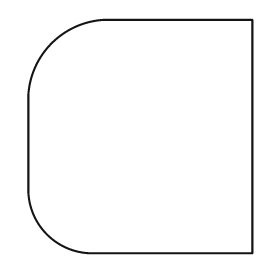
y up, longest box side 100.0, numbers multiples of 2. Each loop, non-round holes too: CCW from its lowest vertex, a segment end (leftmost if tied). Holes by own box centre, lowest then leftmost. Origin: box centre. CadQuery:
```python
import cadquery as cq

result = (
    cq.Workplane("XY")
    .moveTo(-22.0, -50.0)
    .lineTo(48.0, -50.0)
    .lineTo(48.0, 50.0)
    .lineTo(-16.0, 50.0)
    .threePointArc((-38.0, 40.0), (-48.0, 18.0))
    .lineTo(-48.0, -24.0)
    .threePointArc((-40.0, -42.0), (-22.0, -50.0))
    .close()
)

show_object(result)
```